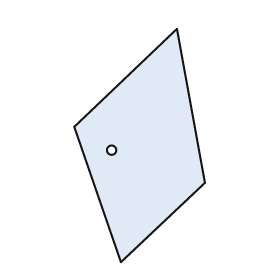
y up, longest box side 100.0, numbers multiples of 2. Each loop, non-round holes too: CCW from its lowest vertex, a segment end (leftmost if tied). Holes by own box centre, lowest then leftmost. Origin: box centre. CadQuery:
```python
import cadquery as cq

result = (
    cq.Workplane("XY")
    .moveTo(-8.0, -50.0)
    .lineTo(28.0, -16.0)
    .lineTo(16.0, 50.0)
    .lineTo(-28.0, 8.0)
    .close()
    .moveTo(-12.0, -2.0)
    .circle(2.0)
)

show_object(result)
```